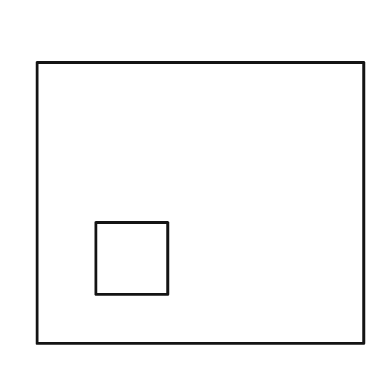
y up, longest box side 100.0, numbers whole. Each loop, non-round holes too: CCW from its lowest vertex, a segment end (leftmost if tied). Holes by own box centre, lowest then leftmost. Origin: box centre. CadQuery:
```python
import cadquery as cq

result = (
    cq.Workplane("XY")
    .moveTo(-50.0, -43.0)
    .lineTo(50.0, -43.0)
    .lineTo(50.0, 43.0)
    .lineTo(-50.0, 43.0)
    .close()
    .moveTo(-32.0, -28.0)
    .lineTo(-10.0, -28.0)
    .lineTo(-10.0, -6.0)
    .lineTo(-32.0, -6.0)
    .close()
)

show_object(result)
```